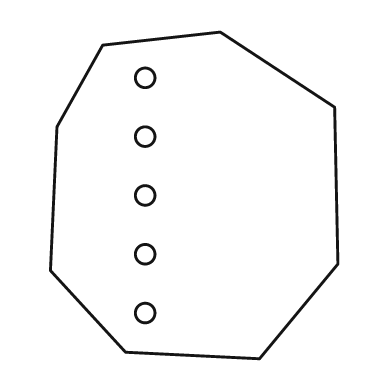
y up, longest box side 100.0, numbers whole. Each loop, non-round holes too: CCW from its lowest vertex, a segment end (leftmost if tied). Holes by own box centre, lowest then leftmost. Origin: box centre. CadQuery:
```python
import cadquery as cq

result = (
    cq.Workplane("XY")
    .moveTo(20.0, -50.0)
    .lineTo(44.0, -21.0)
    .lineTo(43.0, 27.0)
    .lineTo(8.0, 50.0)
    .lineTo(-28.0, 46.0)
    .lineTo(-42.0, 21.0)
    .lineTo(-44.0, -23.0)
    .lineTo(-21.0, -48.0)
    .close()
    .moveTo(-15.0, -36.0)
    .circle(3.0)
    .moveTo(-15.0, -18.0)
    .circle(3.0)
    .moveTo(-15.0, 0.0)
    .circle(3.0)
    .moveTo(-15.0, 18.0)
    .circle(3.0)
    .moveTo(-15.0, 36.0)
    .circle(3.0)
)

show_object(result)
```